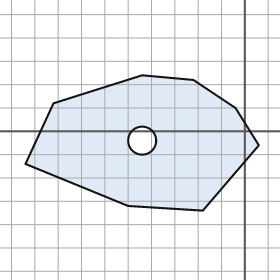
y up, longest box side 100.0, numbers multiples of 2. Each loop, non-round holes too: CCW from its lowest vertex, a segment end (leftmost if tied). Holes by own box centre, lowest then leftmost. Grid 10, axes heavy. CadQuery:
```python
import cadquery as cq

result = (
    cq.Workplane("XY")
    .moveTo(-18.0, -34.0)
    .lineTo(6.0, -6.0)
    .lineTo(-4.0, 10.0)
    .lineTo(-22.0, 22.0)
    .lineTo(-44.0, 24.0)
    .lineTo(-82.0, 12.0)
    .lineTo(-94.0, -14.0)
    .lineTo(-50.0, -32.0)
    .close()
    .moveTo(-44.0, -4.0)
    .circle(6.0)
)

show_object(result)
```